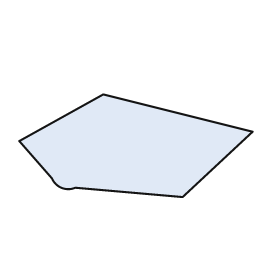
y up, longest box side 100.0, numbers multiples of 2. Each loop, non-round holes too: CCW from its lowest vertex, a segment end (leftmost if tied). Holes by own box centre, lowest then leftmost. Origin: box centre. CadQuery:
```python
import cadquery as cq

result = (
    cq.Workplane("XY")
    .moveTo(20.0, -22.0)
    .lineTo(50.0, 6.0)
    .lineTo(-14.0, 22.0)
    .lineTo(-50.0, 2.0)
    .lineTo(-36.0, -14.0)
    .threePointArc((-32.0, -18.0), (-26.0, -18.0))
    .close()
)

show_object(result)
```